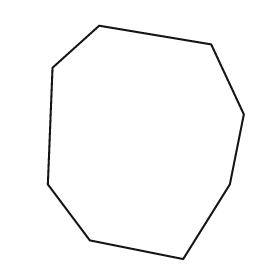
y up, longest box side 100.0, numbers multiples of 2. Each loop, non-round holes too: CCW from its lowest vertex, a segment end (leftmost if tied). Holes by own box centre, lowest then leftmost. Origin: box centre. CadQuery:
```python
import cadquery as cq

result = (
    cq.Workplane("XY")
    .moveTo(16.0, -50.0)
    .lineTo(36.0, -18.0)
    .lineTo(42.0, 12.0)
    .lineTo(28.0, 42.0)
    .lineTo(-20.0, 50.0)
    .lineTo(-40.0, 32.0)
    .lineTo(-42.0, -18.0)
    .lineTo(-24.0, -42.0)
    .close()
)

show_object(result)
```